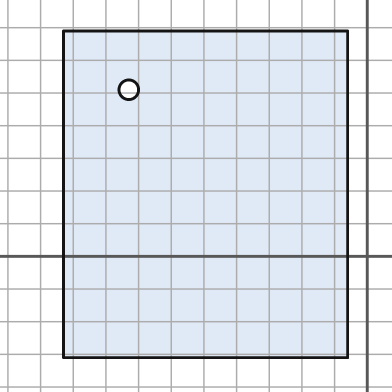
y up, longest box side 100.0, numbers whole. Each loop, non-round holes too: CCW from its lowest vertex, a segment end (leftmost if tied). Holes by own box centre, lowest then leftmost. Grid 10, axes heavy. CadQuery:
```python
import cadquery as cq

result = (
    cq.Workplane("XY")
    .moveTo(-93.0, -31.0)
    .lineTo(-6.0, -31.0)
    .lineTo(-6.0, 69.0)
    .lineTo(-93.0, 69.0)
    .close()
    .moveTo(-73.0, 51.0)
    .circle(3.0)
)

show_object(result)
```